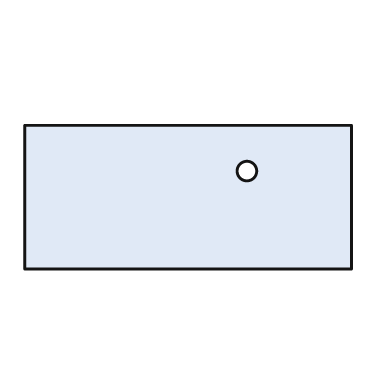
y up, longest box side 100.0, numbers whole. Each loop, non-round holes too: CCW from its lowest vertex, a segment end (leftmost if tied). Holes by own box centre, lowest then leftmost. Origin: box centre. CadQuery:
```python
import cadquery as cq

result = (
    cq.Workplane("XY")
    .moveTo(-50.0, -22.0)
    .lineTo(50.0, -22.0)
    .lineTo(50.0, 22.0)
    .lineTo(-50.0, 22.0)
    .close()
    .moveTo(18.0, 8.0)
    .circle(3.0)
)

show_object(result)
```